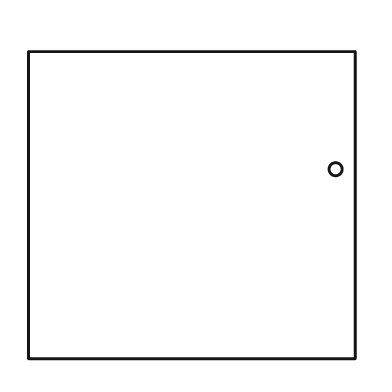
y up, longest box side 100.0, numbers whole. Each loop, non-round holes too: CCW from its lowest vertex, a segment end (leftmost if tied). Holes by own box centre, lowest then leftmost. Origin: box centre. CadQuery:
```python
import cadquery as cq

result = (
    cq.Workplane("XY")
    .moveTo(-50.0, -47.0)
    .lineTo(50.0, -47.0)
    .lineTo(50.0, 47.0)
    .lineTo(-50.0, 47.0)
    .close()
    .moveTo(44.0, 11.0)
    .circle(2.0)
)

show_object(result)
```